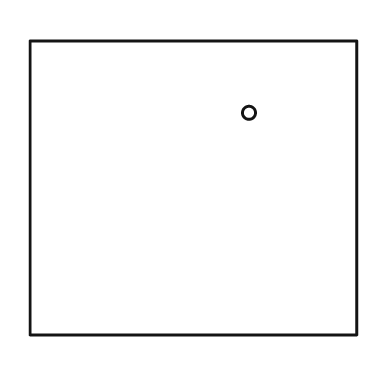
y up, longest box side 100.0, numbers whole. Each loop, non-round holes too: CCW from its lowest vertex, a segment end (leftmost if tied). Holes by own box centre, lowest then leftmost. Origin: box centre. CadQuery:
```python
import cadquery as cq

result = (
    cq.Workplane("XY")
    .moveTo(-50.0, -45.0)
    .lineTo(50.0, -45.0)
    .lineTo(50.0, 45.0)
    .lineTo(-50.0, 45.0)
    .close()
    .moveTo(17.0, 23.0)
    .circle(2.0)
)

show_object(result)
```